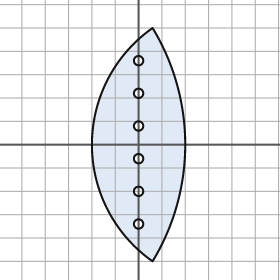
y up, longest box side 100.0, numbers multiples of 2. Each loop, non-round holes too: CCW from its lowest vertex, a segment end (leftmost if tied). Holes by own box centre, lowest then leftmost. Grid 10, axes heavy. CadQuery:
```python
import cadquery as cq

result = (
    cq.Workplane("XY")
    .moveTo(6.0, -50.0)
    .threePointArc((20.0, 0.0), (6.0, 50.0))
    .threePointArc((-20.0, 0.0), (6.0, -50.0))
    .close()
    .moveTo(0.0, -34.0)
    .circle(2.0)
    .moveTo(0.0, -20.0)
    .circle(2.0)
    .moveTo(0.0, -6.0)
    .circle(2.0)
    .moveTo(0.0, 8.0)
    .circle(2.0)
    .moveTo(0.0, 22.0)
    .circle(2.0)
    .moveTo(0.0, 36.0)
    .circle(2.0)
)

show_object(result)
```